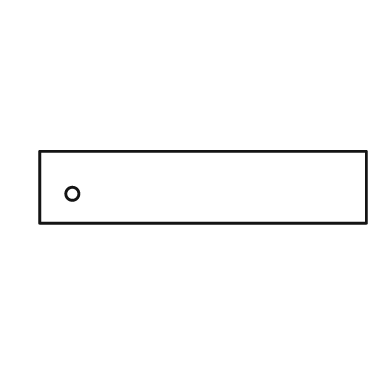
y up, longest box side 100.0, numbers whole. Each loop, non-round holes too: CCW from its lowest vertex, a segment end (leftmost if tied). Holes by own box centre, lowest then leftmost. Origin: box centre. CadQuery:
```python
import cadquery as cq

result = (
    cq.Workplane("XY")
    .moveTo(-50.0, -11.0)
    .lineTo(50.0, -11.0)
    .lineTo(50.0, 11.0)
    .lineTo(-50.0, 11.0)
    .close()
    .moveTo(-40.0, -2.0)
    .circle(2.0)
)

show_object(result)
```